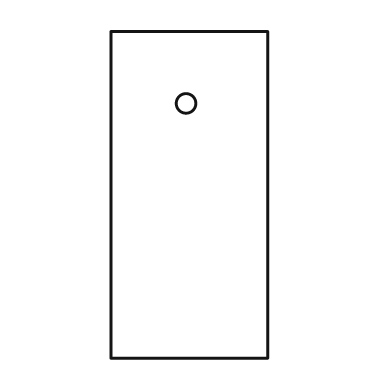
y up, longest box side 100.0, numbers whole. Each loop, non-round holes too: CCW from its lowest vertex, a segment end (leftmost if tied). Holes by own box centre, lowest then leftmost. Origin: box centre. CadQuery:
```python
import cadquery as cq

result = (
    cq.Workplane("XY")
    .moveTo(-24.0, -50.0)
    .lineTo(24.0, -50.0)
    .lineTo(24.0, 50.0)
    .lineTo(-24.0, 50.0)
    .close()
    .moveTo(-1.0, 28.0)
    .circle(3.0)
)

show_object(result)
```